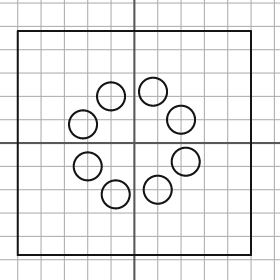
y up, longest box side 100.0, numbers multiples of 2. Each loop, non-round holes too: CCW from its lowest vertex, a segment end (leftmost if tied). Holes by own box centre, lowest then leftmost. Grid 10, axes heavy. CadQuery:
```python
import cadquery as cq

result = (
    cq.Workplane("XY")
    .moveTo(-50.0, -48.0)
    .lineTo(50.0, -48.0)
    .lineTo(50.0, 48.0)
    .lineTo(-50.0, 48.0)
    .close()
    .moveTo(-8.0, -22.0)
    .circle(6.0)
    .moveTo(10.0, -20.0)
    .circle(6.0)
    .moveTo(-20.0, -10.0)
    .circle(6.0)
    .moveTo(22.0, -8.0)
    .circle(6.0)
    .moveTo(-22.0, 8.0)
    .circle(6.0)
    .moveTo(20.0, 10.0)
    .circle(6.0)
    .moveTo(-10.0, 20.0)
    .circle(6.0)
    .moveTo(8.0, 22.0)
    .circle(6.0)
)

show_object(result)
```